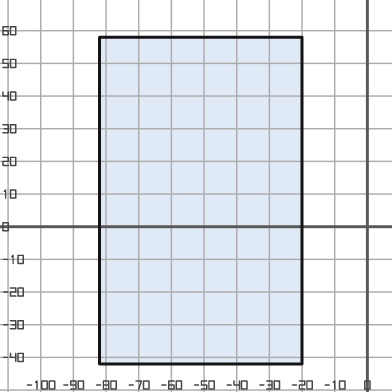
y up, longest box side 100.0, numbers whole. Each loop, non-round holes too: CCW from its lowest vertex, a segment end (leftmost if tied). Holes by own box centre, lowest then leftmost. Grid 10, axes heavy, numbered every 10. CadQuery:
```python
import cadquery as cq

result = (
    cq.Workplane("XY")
    .moveTo(-82.0, -42.0)
    .lineTo(-20.0, -42.0)
    .lineTo(-20.0, 58.0)
    .lineTo(-82.0, 58.0)
    .close()
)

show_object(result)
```